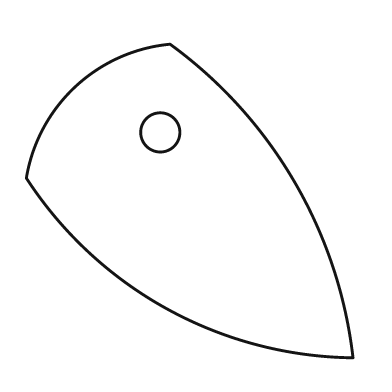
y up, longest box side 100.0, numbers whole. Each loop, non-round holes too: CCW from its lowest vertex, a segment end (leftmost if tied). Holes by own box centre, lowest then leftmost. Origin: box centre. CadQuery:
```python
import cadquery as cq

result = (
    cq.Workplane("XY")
    .moveTo(50.0, -48.0)
    .threePointArc((32.0, 6.0), (-6.0, 48.0))
    .threePointArc((-35.0, 35.0), (-50.0, 7.0))
    .threePointArc((-7.0, -33.0), (50.0, -48.0))
    .close()
    .moveTo(-9.0, 21.0)
    .circle(6.0)
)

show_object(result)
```